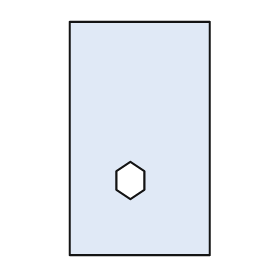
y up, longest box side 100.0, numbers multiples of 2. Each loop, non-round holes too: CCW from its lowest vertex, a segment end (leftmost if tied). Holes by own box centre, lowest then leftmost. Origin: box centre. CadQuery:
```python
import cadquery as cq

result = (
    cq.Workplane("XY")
    .moveTo(-30.0, -50.0)
    .lineTo(30.0, -50.0)
    .lineTo(30.0, 50.0)
    .lineTo(-30.0, 50.0)
    .close()
    .moveTo(-4.0, -26.0)
    .lineTo(2.0, -22.0)
    .lineTo(2.0, -14.0)
    .lineTo(-4.0, -10.0)
    .lineTo(-10.0, -14.0)
    .lineTo(-10.0, -22.0)
    .close()
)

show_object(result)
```